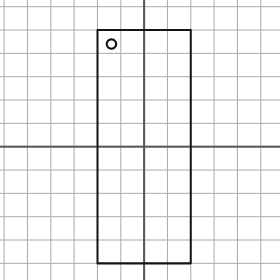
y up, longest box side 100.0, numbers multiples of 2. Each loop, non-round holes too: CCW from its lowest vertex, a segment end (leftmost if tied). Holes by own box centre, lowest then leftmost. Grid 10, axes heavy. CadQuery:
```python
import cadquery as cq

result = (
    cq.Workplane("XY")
    .moveTo(-20.0, -50.0)
    .lineTo(20.0, -50.0)
    .lineTo(20.0, 50.0)
    .lineTo(-20.0, 50.0)
    .close()
    .moveTo(-14.0, 44.0)
    .circle(2.0)
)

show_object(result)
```